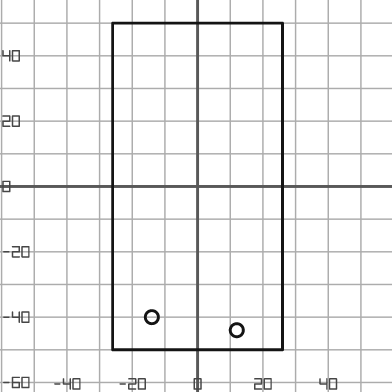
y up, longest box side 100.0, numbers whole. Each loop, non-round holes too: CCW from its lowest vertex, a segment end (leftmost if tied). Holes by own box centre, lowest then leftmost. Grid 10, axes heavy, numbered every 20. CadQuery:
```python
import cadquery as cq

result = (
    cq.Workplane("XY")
    .moveTo(-26.0, -50.0)
    .lineTo(26.0, -50.0)
    .lineTo(26.0, 50.0)
    .lineTo(-26.0, 50.0)
    .close()
    .moveTo(12.0, -44.0)
    .circle(2.0)
    .moveTo(-14.0, -40.0)
    .circle(2.0)
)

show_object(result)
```